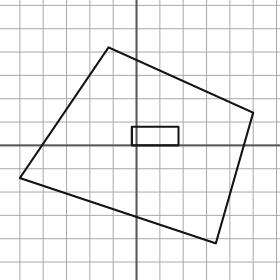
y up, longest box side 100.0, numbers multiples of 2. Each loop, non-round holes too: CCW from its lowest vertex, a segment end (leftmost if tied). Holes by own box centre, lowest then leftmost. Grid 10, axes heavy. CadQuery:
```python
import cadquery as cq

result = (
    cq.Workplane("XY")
    .moveTo(34.0, -42.0)
    .lineTo(50.0, 14.0)
    .lineTo(-12.0, 42.0)
    .lineTo(-50.0, -14.0)
    .close()
    .moveTo(-2.0, 0.0)
    .lineTo(18.0, 0.0)
    .lineTo(18.0, 8.0)
    .lineTo(-2.0, 8.0)
    .close()
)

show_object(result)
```